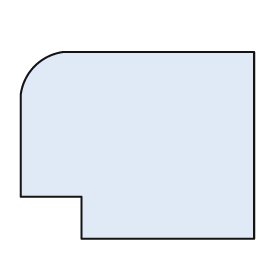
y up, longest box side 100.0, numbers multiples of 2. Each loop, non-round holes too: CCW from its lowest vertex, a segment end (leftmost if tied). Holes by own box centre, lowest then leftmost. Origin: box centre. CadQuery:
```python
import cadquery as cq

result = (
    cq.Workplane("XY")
    .moveTo(-24.0, -40.0)
    .lineTo(50.0, -40.0)
    .lineTo(50.0, 40.0)
    .lineTo(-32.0, 40.0)
    .threePointArc((-44.0, 34.0), (-50.0, 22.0))
    .lineTo(-50.0, -22.0)
    .lineTo(-24.0, -22.0)
    .close()
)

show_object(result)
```